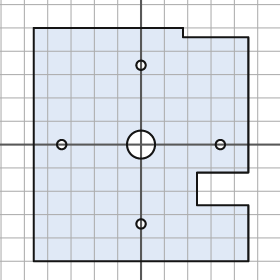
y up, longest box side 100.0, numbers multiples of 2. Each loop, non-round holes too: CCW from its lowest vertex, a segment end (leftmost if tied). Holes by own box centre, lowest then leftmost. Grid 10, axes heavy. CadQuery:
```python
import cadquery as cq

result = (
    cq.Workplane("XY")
    .moveTo(-46.0, -50.0)
    .lineTo(46.0, -50.0)
    .lineTo(46.0, -26.0)
    .lineTo(24.0, -26.0)
    .lineTo(24.0, -12.0)
    .lineTo(46.0, -12.0)
    .lineTo(46.0, 46.0)
    .lineTo(18.0, 46.0)
    .lineTo(18.0, 50.0)
    .lineTo(-46.0, 50.0)
    .close()
    .moveTo(0.0, -34.0)
    .circle(2.0)
    .moveTo(-34.0, 0.0)
    .circle(2.0)
    .moveTo(0.0, 0.0)
    .circle(6.0)
    .moveTo(34.0, 0.0)
    .circle(2.0)
    .moveTo(0.0, 34.0)
    .circle(2.0)
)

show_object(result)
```